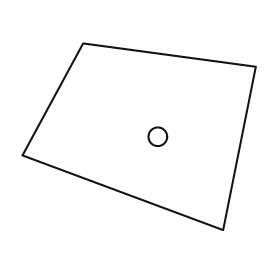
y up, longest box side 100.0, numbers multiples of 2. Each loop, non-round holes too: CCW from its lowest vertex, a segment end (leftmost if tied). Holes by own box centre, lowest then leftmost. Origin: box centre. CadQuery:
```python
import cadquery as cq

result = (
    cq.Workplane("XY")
    .moveTo(36.0, -40.0)
    .lineTo(50.0, 30.0)
    .lineTo(-24.0, 40.0)
    .lineTo(-50.0, -8.0)
    .close()
    .moveTo(8.0, 0.0)
    .circle(4.0)
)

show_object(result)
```